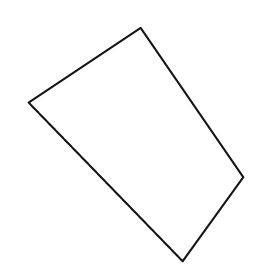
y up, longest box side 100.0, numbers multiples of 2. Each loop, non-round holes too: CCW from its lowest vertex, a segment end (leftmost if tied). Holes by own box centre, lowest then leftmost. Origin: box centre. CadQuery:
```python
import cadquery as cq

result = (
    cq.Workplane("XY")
    .moveTo(20.0, -50.0)
    .lineTo(46.0, -14.0)
    .lineTo(2.0, 50.0)
    .lineTo(-46.0, 18.0)
    .close()
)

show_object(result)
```